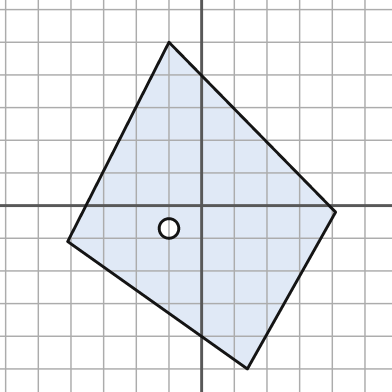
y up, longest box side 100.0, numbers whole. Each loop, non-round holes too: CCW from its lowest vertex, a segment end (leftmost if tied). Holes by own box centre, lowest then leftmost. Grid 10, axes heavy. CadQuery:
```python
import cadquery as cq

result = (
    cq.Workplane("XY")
    .moveTo(14.0, -50.0)
    .lineTo(41.0, -2.0)
    .lineTo(-10.0, 50.0)
    .lineTo(-41.0, -11.0)
    .close()
    .moveTo(-10.0, -7.0)
    .circle(3.0)
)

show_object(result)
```